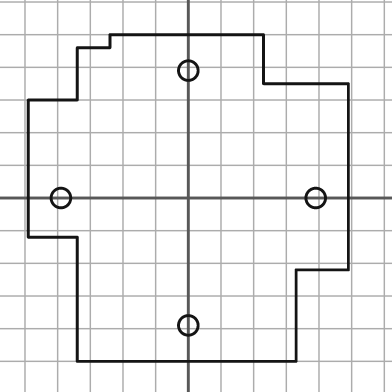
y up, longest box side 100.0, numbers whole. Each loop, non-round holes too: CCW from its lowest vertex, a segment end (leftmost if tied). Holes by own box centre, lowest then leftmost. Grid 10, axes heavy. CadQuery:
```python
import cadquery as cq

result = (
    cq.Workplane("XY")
    .moveTo(-34.0, -50.0)
    .lineTo(33.0, -50.0)
    .lineTo(33.0, -22.0)
    .lineTo(49.0, -22.0)
    .lineTo(49.0, 35.0)
    .lineTo(23.0, 35.0)
    .lineTo(23.0, 50.0)
    .lineTo(-24.0, 50.0)
    .lineTo(-24.0, 46.0)
    .lineTo(-34.0, 46.0)
    .lineTo(-34.0, 30.0)
    .lineTo(-49.0, 30.0)
    .lineTo(-49.0, -12.0)
    .lineTo(-34.0, -12.0)
    .close()
    .moveTo(0.0, -39.0)
    .circle(3.0)
    .moveTo(-39.0, 0.0)
    .circle(3.0)
    .moveTo(39.0, 0.0)
    .circle(3.0)
    .moveTo(0.0, 39.0)
    .circle(3.0)
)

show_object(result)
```